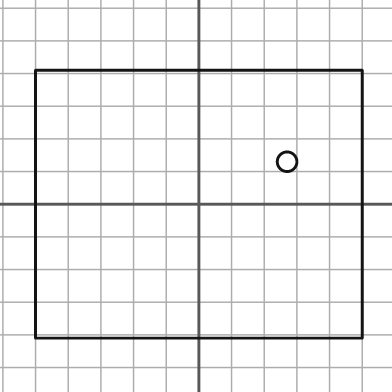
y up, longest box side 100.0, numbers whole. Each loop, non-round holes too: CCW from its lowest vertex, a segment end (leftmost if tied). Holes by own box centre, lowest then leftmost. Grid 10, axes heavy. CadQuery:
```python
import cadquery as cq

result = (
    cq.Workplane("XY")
    .moveTo(-50.0, -41.0)
    .lineTo(50.0, -41.0)
    .lineTo(50.0, 41.0)
    .lineTo(-50.0, 41.0)
    .close()
    .moveTo(27.0, 13.0)
    .circle(3.0)
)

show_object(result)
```